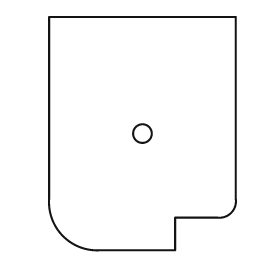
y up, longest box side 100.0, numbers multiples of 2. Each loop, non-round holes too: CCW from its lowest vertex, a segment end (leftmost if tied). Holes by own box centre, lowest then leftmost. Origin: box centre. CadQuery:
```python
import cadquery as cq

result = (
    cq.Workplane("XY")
    .moveTo(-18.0, -50.0)
    .lineTo(14.0, -50.0)
    .lineTo(14.0, -36.0)
    .lineTo(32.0, -36.0)
    .threePointArc((38.0, -34.0), (40.0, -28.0))
    .lineTo(40.0, 50.0)
    .lineTo(-40.0, 50.0)
    .lineTo(-40.0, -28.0)
    .threePointArc((-34.0, -44.0), (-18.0, -50.0))
    .close()
    .moveTo(0.0, 0.0)
    .circle(4.0)
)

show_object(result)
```